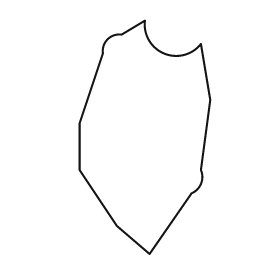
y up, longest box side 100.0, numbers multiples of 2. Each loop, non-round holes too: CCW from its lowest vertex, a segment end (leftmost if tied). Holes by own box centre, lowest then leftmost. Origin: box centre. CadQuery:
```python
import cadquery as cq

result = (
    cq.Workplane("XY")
    .moveTo(2.0, -50.0)
    .lineTo(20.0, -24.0)
    .threePointArc((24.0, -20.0), (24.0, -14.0))
    .lineTo(28.0, 16.0)
    .lineTo(24.0, 40.0)
    .threePointArc((8.0, 36.0), (0.0, 50.0))
    .lineTo(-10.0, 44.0)
    .threePointArc((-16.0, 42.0), (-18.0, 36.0))
    .lineTo(-28.0, 6.0)
    .lineTo(-28.0, -14.0)
    .lineTo(-12.0, -38.0)
    .close()
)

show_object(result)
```